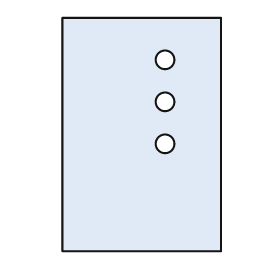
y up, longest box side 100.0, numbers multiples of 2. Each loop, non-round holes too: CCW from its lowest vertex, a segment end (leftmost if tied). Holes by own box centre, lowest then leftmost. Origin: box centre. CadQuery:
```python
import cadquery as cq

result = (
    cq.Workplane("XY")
    .moveTo(-34.0, -50.0)
    .lineTo(34.0, -50.0)
    .lineTo(34.0, 50.0)
    .lineTo(-34.0, 50.0)
    .close()
    .moveTo(10.0, -4.0)
    .circle(4.0)
    .moveTo(10.0, 14.0)
    .circle(4.0)
    .moveTo(10.0, 32.0)
    .circle(4.0)
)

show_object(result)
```